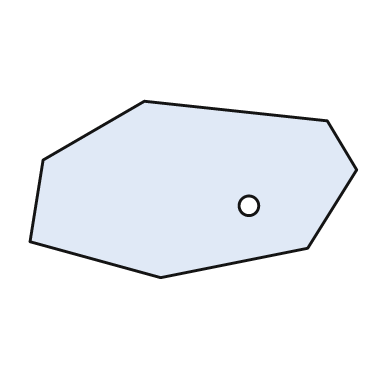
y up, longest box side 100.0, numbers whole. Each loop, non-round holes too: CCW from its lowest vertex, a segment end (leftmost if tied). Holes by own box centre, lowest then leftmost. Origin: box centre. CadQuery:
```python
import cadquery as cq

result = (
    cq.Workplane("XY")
    .moveTo(-10.0, -27.0)
    .lineTo(35.0, -18.0)
    .lineTo(50.0, 6.0)
    .lineTo(41.0, 21.0)
    .lineTo(-15.0, 27.0)
    .lineTo(-46.0, 9.0)
    .lineTo(-50.0, -16.0)
    .close()
    .moveTo(17.0, -5.0)
    .circle(3.0)
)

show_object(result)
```